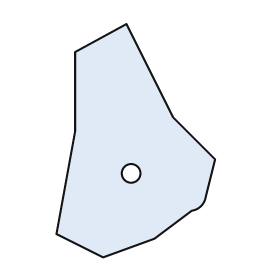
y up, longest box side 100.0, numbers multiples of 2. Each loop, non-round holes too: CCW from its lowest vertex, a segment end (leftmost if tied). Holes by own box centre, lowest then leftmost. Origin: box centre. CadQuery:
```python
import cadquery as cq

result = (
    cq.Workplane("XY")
    .moveTo(-14.0, -50.0)
    .lineTo(8.0, -42.0)
    .lineTo(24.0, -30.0)
    .threePointArc((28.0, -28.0), (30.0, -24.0))
    .lineTo(34.0, -8.0)
    .lineTo(16.0, 10.0)
    .lineTo(-4.0, 50.0)
    .lineTo(-26.0, 38.0)
    .lineTo(-26.0, 4.0)
    .lineTo(-34.0, -40.0)
    .close()
    .moveTo(-2.0, -14.0)
    .circle(4.0)
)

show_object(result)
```